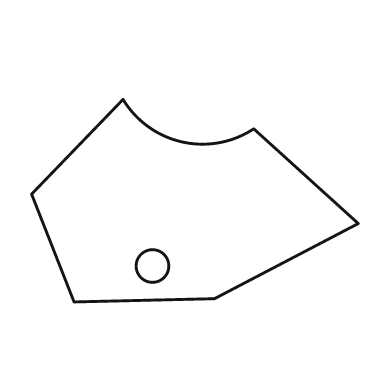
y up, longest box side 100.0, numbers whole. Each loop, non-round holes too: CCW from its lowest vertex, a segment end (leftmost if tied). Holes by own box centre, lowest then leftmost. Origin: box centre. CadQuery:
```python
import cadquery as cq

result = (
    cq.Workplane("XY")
    .moveTo(-37.0, -31.0)
    .lineTo(6.0, -30.0)
    .lineTo(50.0, -7.0)
    .lineTo(18.0, 22.0)
    .threePointArc((-4.0, 18.0), (-22.0, 31.0))
    .lineTo(-50.0, 2.0)
    .close()
    .moveTo(-13.0, -20.0)
    .circle(5.0)
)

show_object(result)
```